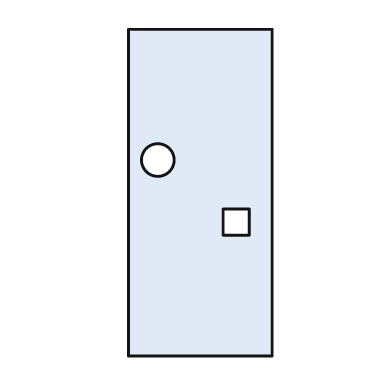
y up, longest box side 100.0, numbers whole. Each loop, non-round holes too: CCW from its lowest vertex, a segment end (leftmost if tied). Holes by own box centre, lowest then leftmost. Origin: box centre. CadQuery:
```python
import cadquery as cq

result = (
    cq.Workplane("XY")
    .moveTo(-22.0, -50.0)
    .lineTo(22.0, -50.0)
    .lineTo(22.0, 50.0)
    .lineTo(-22.0, 50.0)
    .close()
    .moveTo(7.0, -13.0)
    .lineTo(15.0, -13.0)
    .lineTo(15.0, -5.0)
    .lineTo(7.0, -5.0)
    .close()
    .moveTo(-13.0, 10.0)
    .circle(5.0)
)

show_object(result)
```